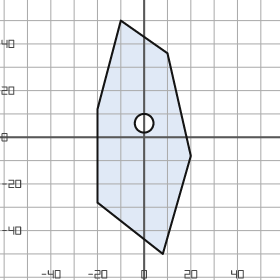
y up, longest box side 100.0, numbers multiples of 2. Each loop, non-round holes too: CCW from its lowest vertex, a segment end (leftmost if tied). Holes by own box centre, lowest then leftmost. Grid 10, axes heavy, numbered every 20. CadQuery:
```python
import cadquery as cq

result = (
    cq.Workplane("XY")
    .moveTo(8.0, -50.0)
    .lineTo(20.0, -8.0)
    .lineTo(10.0, 36.0)
    .lineTo(-10.0, 50.0)
    .lineTo(-20.0, 12.0)
    .lineTo(-20.0, -28.0)
    .close()
    .moveTo(0.0, 6.0)
    .circle(4.0)
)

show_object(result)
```